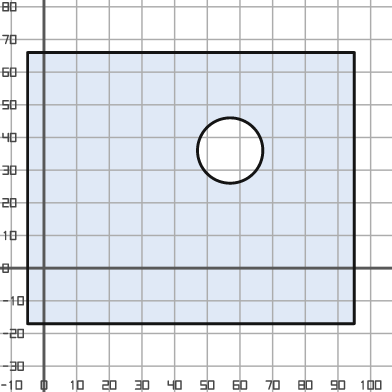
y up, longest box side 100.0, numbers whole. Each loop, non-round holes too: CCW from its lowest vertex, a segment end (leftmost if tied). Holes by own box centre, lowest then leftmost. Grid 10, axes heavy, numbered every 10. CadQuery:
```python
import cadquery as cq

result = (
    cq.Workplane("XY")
    .moveTo(-5.0, -17.0)
    .lineTo(95.0, -17.0)
    .lineTo(95.0, 66.0)
    .lineTo(-5.0, 66.0)
    .close()
    .moveTo(57.0, 36.0)
    .circle(10.0)
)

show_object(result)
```